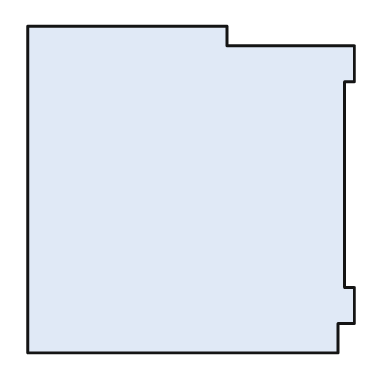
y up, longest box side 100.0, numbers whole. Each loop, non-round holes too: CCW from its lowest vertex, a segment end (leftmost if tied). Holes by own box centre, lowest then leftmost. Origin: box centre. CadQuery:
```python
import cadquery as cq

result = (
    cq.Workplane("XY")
    .moveTo(-50.0, -50.0)
    .lineTo(45.0, -50.0)
    .lineTo(45.0, -41.0)
    .lineTo(50.0, -41.0)
    .lineTo(50.0, -30.0)
    .lineTo(47.0, -30.0)
    .lineTo(47.0, 33.0)
    .lineTo(50.0, 33.0)
    .lineTo(50.0, 44.0)
    .lineTo(11.0, 44.0)
    .lineTo(11.0, 50.0)
    .lineTo(-50.0, 50.0)
    .close()
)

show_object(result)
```